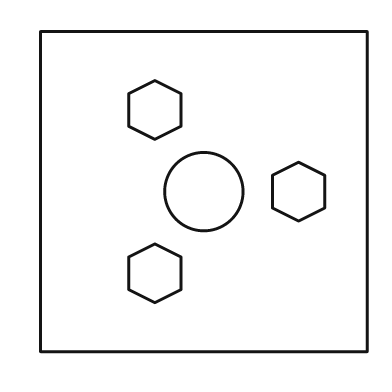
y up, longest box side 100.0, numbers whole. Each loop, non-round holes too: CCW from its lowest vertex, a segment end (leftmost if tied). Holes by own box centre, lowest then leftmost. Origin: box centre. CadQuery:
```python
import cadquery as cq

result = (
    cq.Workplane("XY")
    .moveTo(-50.0, -49.0)
    .lineTo(50.0, -49.0)
    .lineTo(50.0, 49.0)
    .lineTo(-50.0, 49.0)
    .close()
    .moveTo(-15.0, -34.0)
    .lineTo(-7.0, -30.0)
    .lineTo(-7.0, -20.0)
    .lineTo(-15.0, -16.0)
    .lineTo(-23.0, -20.0)
    .lineTo(-23.0, -30.0)
    .close()
    .moveTo(0.0, 0.0)
    .circle(12.0)
    .moveTo(29.0, -9.0)
    .lineTo(37.0, -5.0)
    .lineTo(37.0, 5.0)
    .lineTo(29.0, 9.0)
    .lineTo(21.0, 5.0)
    .lineTo(21.0, -5.0)
    .close()
    .moveTo(-15.0, 16.0)
    .lineTo(-7.0, 20.0)
    .lineTo(-7.0, 30.0)
    .lineTo(-15.0, 34.0)
    .lineTo(-23.0, 30.0)
    .lineTo(-23.0, 20.0)
    .close()
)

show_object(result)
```